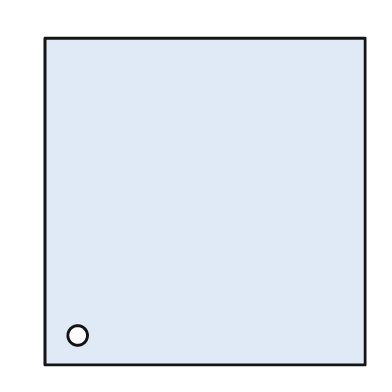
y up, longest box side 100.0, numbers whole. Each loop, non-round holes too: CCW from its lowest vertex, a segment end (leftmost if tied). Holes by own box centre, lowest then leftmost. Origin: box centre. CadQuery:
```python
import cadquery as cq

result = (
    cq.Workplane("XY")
    .moveTo(-49.0, -50.0)
    .lineTo(49.0, -50.0)
    .lineTo(49.0, 50.0)
    .lineTo(-49.0, 50.0)
    .close()
    .moveTo(-39.0, -41.0)
    .circle(3.0)
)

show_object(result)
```